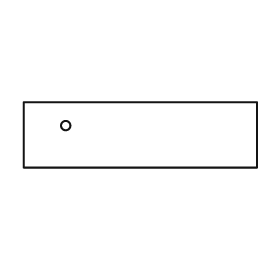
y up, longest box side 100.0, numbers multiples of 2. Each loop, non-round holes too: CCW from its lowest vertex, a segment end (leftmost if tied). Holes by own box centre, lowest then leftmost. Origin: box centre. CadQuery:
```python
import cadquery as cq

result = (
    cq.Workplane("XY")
    .moveTo(-50.0, -14.0)
    .lineTo(50.0, -14.0)
    .lineTo(50.0, 14.0)
    .lineTo(-50.0, 14.0)
    .close()
    .moveTo(-32.0, 4.0)
    .circle(2.0)
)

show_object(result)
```